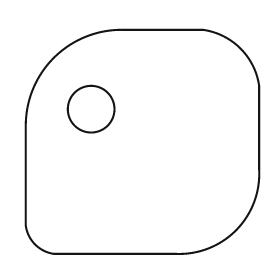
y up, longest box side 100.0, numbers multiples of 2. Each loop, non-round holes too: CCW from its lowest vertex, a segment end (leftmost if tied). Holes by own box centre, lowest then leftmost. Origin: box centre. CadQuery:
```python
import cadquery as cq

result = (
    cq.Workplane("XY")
    .moveTo(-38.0, -48.0)
    .lineTo(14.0, -48.0)
    .threePointArc((40.0, -38.0), (50.0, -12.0))
    .lineTo(50.0, 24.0)
    .threePointArc((42.0, 40.0), (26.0, 48.0))
    .lineTo(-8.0, 48.0)
    .threePointArc((-38.0, 36.0), (-50.0, 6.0))
    .lineTo(-50.0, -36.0)
    .threePointArc((-46.0, -44.0), (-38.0, -48.0))
    .close()
    .moveTo(-22.0, 14.0)
    .circle(10.0)
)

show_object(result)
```